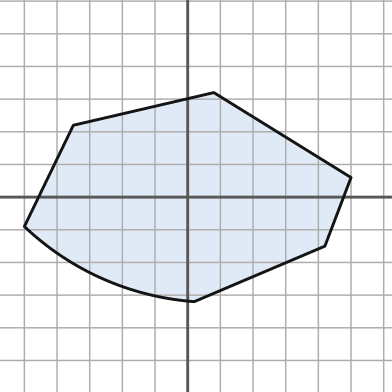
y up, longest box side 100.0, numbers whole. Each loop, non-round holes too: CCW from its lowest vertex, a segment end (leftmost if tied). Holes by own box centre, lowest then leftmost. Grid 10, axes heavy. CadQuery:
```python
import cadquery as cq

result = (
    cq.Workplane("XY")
    .moveTo(2.0, -32.0)
    .lineTo(42.0, -15.0)
    .lineTo(50.0, 6.0)
    .lineTo(8.0, 32.0)
    .lineTo(-35.0, 22.0)
    .lineTo(-50.0, -9.0)
    .threePointArc((-26.0, -25.0), (2.0, -32.0))
    .close()
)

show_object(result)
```